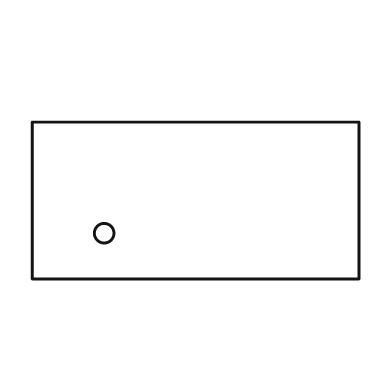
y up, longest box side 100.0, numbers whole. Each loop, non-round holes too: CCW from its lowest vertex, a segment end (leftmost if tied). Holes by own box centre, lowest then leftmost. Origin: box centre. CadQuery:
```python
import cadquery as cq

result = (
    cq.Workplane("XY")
    .moveTo(-50.0, -24.0)
    .lineTo(50.0, -24.0)
    .lineTo(50.0, 24.0)
    .lineTo(-50.0, 24.0)
    .close()
    .moveTo(-28.0, -10.0)
    .circle(3.0)
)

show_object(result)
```